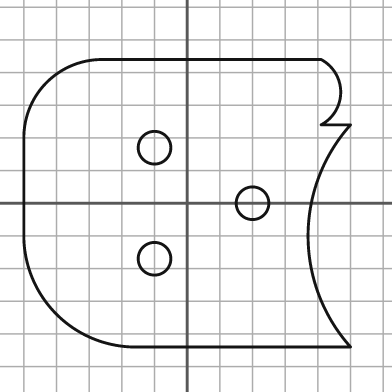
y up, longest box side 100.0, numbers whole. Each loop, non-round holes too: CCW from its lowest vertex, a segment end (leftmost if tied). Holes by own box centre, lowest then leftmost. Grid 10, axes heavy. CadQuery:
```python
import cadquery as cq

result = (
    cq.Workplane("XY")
    .moveTo(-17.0, -44.0)
    .lineTo(50.0, -44.0)
    .threePointArc((37.0, -10.0), (50.0, 24.0))
    .lineTo(41.0, 24.0)
    .threePointArc((47.0, 34.0), (41.0, 44.0))
    .lineTo(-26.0, 44.0)
    .threePointArc((-43.0, 37.0), (-50.0, 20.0))
    .lineTo(-50.0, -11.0)
    .threePointArc((-40.0, -34.0), (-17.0, -44.0))
    .close()
    .moveTo(-10.0, -17.0)
    .circle(5.0)
    .moveTo(20.0, 0.0)
    .circle(5.0)
    .moveTo(-10.0, 17.0)
    .circle(5.0)
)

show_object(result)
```